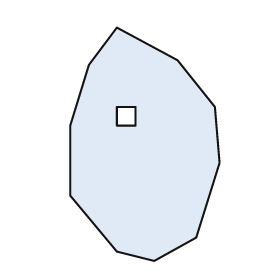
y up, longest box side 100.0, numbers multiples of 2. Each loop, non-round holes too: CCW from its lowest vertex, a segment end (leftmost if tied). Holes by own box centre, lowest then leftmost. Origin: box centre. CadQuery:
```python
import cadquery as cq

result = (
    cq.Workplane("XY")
    .moveTo(4.0, -50.0)
    .lineTo(22.0, -40.0)
    .lineTo(32.0, -8.0)
    .lineTo(30.0, 16.0)
    .lineTo(14.0, 36.0)
    .lineTo(-12.0, 50.0)
    .lineTo(-24.0, 34.0)
    .lineTo(-32.0, 8.0)
    .lineTo(-32.0, -22.0)
    .lineTo(-12.0, -46.0)
    .close()
    .moveTo(-12.0, 8.0)
    .lineTo(-4.0, 8.0)
    .lineTo(-4.0, 16.0)
    .lineTo(-12.0, 16.0)
    .close()
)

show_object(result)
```